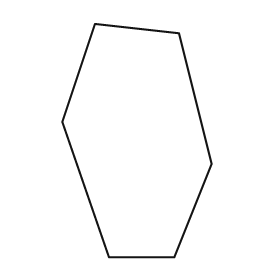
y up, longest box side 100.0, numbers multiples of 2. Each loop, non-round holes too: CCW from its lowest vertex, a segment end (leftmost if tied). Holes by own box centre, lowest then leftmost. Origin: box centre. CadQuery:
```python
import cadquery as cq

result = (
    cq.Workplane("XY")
    .moveTo(-12.0, -50.0)
    .lineTo(16.0, -50.0)
    .lineTo(32.0, -10.0)
    .lineTo(18.0, 46.0)
    .lineTo(-18.0, 50.0)
    .lineTo(-32.0, 8.0)
    .close()
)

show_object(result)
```